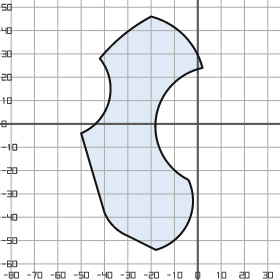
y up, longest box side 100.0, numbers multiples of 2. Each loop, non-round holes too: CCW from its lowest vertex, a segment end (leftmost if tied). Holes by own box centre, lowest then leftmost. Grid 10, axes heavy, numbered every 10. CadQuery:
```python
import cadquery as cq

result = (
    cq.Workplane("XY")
    .moveTo(-18.0, -54.0)
    .threePointArc((-4.0, -42.0), (-4.0, -24.0))
    .threePointArc((-18.0, 2.0), (2.0, 24.0))
    .threePointArc((-6.0, 38.0), (-20.0, 46.0))
    .threePointArc((-32.0, 38.0), (-42.0, 28.0))
    .threePointArc((-38.0, 10.0), (-50.0, -4.0))
    .lineTo(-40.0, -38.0)
    .threePointArc((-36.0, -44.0), (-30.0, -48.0))
    .close()
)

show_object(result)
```